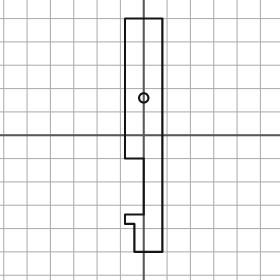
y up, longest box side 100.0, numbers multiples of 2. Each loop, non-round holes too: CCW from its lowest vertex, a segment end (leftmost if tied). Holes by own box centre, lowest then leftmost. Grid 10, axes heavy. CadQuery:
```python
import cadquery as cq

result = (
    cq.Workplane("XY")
    .moveTo(-4.0, -50.0)
    .lineTo(8.0, -50.0)
    .lineTo(8.0, 50.0)
    .lineTo(-8.0, 50.0)
    .lineTo(-8.0, -10.0)
    .lineTo(0.0, -10.0)
    .lineTo(0.0, -34.0)
    .lineTo(-8.0, -34.0)
    .lineTo(-8.0, -38.0)
    .lineTo(-4.0, -38.0)
    .close()
    .moveTo(0.0, 16.0)
    .circle(2.0)
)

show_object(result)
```